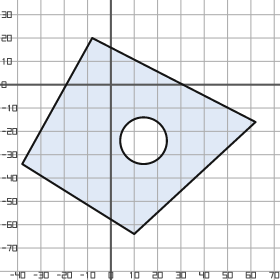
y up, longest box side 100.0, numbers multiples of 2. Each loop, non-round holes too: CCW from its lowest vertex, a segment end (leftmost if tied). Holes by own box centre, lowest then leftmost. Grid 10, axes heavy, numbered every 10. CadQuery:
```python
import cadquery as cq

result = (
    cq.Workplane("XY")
    .moveTo(10.0, -64.0)
    .lineTo(62.0, -16.0)
    .lineTo(-8.0, 20.0)
    .lineTo(-38.0, -34.0)
    .close()
    .moveTo(14.0, -24.0)
    .circle(10.0)
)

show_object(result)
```